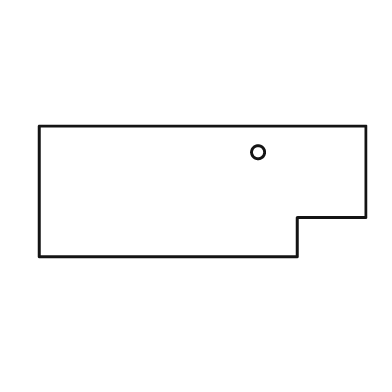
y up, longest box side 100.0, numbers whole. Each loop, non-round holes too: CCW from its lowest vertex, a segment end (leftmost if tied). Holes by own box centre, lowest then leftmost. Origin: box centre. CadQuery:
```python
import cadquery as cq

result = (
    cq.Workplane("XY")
    .moveTo(-50.0, -20.0)
    .lineTo(29.0, -20.0)
    .lineTo(29.0, -8.0)
    .lineTo(50.0, -8.0)
    .lineTo(50.0, 20.0)
    .lineTo(-50.0, 20.0)
    .close()
    .moveTo(17.0, 12.0)
    .circle(2.0)
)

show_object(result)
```